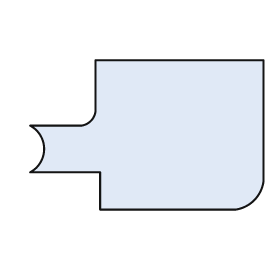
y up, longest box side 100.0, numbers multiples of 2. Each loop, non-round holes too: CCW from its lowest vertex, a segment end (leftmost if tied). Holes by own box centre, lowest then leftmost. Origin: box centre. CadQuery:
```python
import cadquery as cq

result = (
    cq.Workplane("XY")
    .moveTo(-20.0, -32.0)
    .lineTo(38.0, -32.0)
    .threePointArc((46.0, -28.0), (50.0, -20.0))
    .lineTo(50.0, 32.0)
    .lineTo(-22.0, 32.0)
    .lineTo(-22.0, 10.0)
    .threePointArc((-24.0, 6.0), (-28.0, 4.0))
    .lineTo(-50.0, 4.0)
    .threePointArc((-44.0, -6.0), (-50.0, -16.0))
    .lineTo(-20.0, -16.0)
    .close()
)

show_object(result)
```